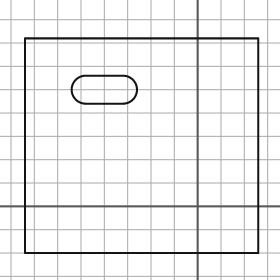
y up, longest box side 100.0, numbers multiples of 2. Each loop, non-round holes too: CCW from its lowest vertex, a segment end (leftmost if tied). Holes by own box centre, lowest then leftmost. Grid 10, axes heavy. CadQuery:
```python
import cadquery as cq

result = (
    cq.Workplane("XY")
    .moveTo(-74.0, -20.0)
    .lineTo(26.0, -20.0)
    .lineTo(26.0, 72.0)
    .lineTo(-74.0, 72.0)
    .close()
    .moveTo(-48.0, 44.0)
    .lineTo(-32.0, 44.0)
    .threePointArc((-26.0, 50.0), (-32.0, 56.0))
    .lineTo(-48.0, 56.0)
    .threePointArc((-54.0, 50.0), (-48.0, 44.0))
    .close()
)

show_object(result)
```